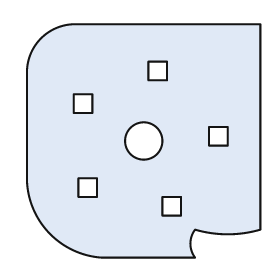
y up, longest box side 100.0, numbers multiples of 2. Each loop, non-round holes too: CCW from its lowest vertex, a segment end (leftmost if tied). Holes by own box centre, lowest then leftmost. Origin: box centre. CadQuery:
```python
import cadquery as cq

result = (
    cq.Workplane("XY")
    .moveTo(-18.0, -50.0)
    .lineTo(22.0, -50.0)
    .threePointArc((20.0, -44.0), (22.0, -38.0))
    .threePointArc((36.0, -40.0), (50.0, -38.0))
    .lineTo(50.0, 50.0)
    .lineTo(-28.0, 50.0)
    .threePointArc((-44.0, 44.0), (-50.0, 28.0))
    .lineTo(-50.0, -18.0)
    .threePointArc((-40.0, -40.0), (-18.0, -50.0))
    .close()
    .moveTo(8.0, -32.0)
    .lineTo(16.0, -32.0)
    .lineTo(16.0, -24.0)
    .lineTo(8.0, -24.0)
    .close()
    .moveTo(-28.0, -24.0)
    .lineTo(-20.0, -24.0)
    .lineTo(-20.0, -16.0)
    .lineTo(-28.0, -16.0)
    .close()
    .moveTo(0.0, 0.0)
    .circle(8.0)
    .moveTo(28.0, -2.0)
    .lineTo(36.0, -2.0)
    .lineTo(36.0, 6.0)
    .lineTo(28.0, 6.0)
    .close()
    .moveTo(-30.0, 12.0)
    .lineTo(-22.0, 12.0)
    .lineTo(-22.0, 20.0)
    .lineTo(-30.0, 20.0)
    .close()
    .moveTo(2.0, 26.0)
    .lineTo(10.0, 26.0)
    .lineTo(10.0, 34.0)
    .lineTo(2.0, 34.0)
    .close()
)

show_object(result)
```